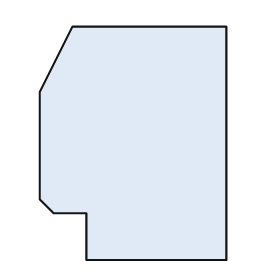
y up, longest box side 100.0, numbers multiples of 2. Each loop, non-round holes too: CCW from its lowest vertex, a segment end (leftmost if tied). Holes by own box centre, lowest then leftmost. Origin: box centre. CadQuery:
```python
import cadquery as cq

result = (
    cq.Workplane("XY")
    .moveTo(-20.0, -50.0)
    .lineTo(40.0, -50.0)
    .lineTo(40.0, 50.0)
    .lineTo(-26.0, 50.0)
    .lineTo(-40.0, 22.0)
    .lineTo(-40.0, -24.0)
    .lineTo(-34.0, -30.0)
    .lineTo(-20.0, -30.0)
    .close()
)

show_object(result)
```